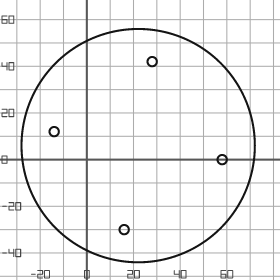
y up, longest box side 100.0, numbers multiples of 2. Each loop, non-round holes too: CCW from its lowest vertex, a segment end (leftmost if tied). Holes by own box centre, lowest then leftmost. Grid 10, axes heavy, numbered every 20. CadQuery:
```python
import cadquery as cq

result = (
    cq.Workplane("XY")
    .moveTo(22.0, 6.0)
    .circle(50.0)
    .moveTo(16.0, -30.0)
    .circle(2.0)
    .moveTo(58.0, 0.0)
    .circle(2.0)
    .moveTo(-14.0, 12.0)
    .circle(2.0)
    .moveTo(28.0, 42.0)
    .circle(2.0)
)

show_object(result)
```